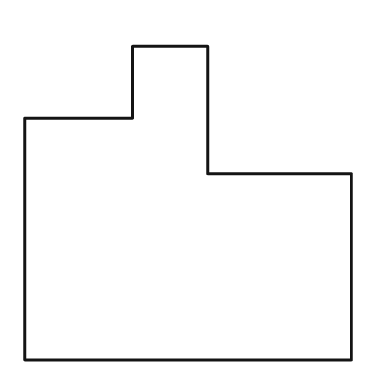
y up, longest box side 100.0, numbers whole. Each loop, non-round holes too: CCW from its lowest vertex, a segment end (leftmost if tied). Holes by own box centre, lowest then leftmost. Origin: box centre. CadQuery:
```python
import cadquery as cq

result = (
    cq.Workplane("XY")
    .moveTo(-50.0, -48.0)
    .lineTo(50.0, -48.0)
    .lineTo(50.0, 9.0)
    .lineTo(6.0, 9.0)
    .lineTo(6.0, 48.0)
    .lineTo(-17.0, 48.0)
    .lineTo(-17.0, 26.0)
    .lineTo(-50.0, 26.0)
    .close()
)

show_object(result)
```